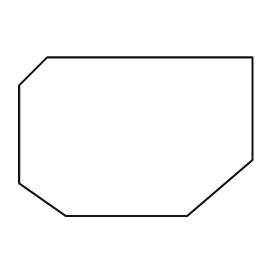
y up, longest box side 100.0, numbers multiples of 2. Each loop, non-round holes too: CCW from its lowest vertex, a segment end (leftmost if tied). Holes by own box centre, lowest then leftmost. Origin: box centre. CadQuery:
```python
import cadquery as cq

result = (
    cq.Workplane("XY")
    .moveTo(-30.0, -34.0)
    .lineTo(22.0, -34.0)
    .lineTo(50.0, -10.0)
    .lineTo(50.0, 34.0)
    .lineTo(-38.0, 34.0)
    .lineTo(-50.0, 22.0)
    .lineTo(-50.0, -20.0)
    .close()
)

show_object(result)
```